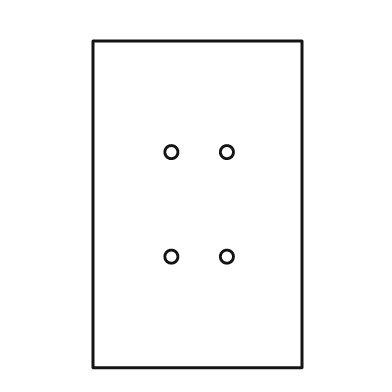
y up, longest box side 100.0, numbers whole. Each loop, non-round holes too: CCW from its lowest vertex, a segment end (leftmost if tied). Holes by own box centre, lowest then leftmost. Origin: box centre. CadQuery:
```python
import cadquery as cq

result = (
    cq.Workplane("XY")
    .moveTo(-32.0, -50.0)
    .lineTo(32.0, -50.0)
    .lineTo(32.0, 50.0)
    .lineTo(-32.0, 50.0)
    .close()
    .moveTo(-8.0, -16.0)
    .circle(2.0)
    .moveTo(9.0, -16.0)
    .circle(2.0)
    .moveTo(-8.0, 16.0)
    .circle(2.0)
    .moveTo(9.0, 16.0)
    .circle(2.0)
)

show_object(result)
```